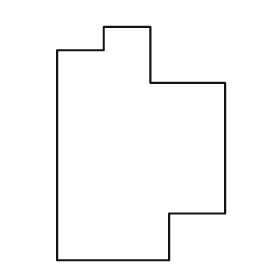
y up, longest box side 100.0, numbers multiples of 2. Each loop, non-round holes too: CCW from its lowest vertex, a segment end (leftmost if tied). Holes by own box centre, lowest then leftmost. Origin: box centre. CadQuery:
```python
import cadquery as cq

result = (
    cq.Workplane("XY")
    .moveTo(-36.0, -50.0)
    .lineTo(12.0, -50.0)
    .lineTo(12.0, -30.0)
    .lineTo(36.0, -30.0)
    .lineTo(36.0, 26.0)
    .lineTo(4.0, 26.0)
    .lineTo(4.0, 50.0)
    .lineTo(-16.0, 50.0)
    .lineTo(-16.0, 40.0)
    .lineTo(-36.0, 40.0)
    .close()
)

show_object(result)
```